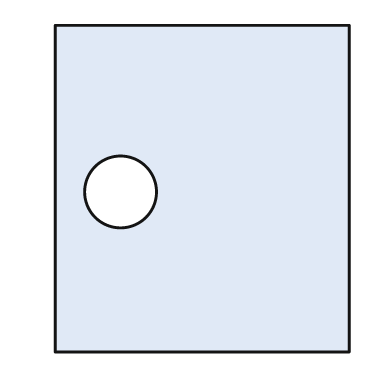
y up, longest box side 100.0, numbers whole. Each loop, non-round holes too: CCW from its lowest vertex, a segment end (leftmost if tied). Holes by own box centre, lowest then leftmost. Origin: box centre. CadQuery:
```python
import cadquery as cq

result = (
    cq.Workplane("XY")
    .moveTo(-45.0, -50.0)
    .lineTo(45.0, -50.0)
    .lineTo(45.0, 50.0)
    .lineTo(-45.0, 50.0)
    .close()
    .moveTo(-25.0, -1.0)
    .circle(11.0)
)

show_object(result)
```